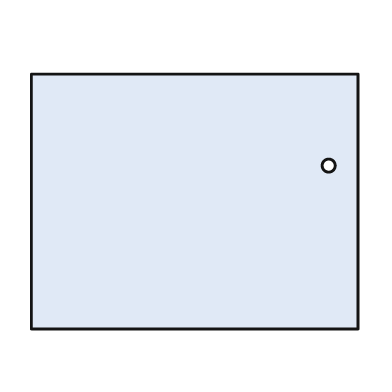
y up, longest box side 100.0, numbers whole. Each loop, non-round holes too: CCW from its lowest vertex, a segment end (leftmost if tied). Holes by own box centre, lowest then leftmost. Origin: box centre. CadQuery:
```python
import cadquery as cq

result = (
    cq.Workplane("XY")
    .moveTo(-50.0, -39.0)
    .lineTo(50.0, -39.0)
    .lineTo(50.0, 39.0)
    .lineTo(-50.0, 39.0)
    .close()
    .moveTo(41.0, 11.0)
    .circle(2.0)
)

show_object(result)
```